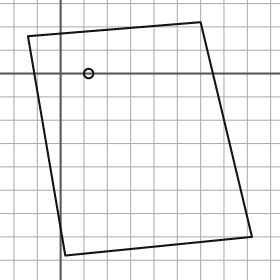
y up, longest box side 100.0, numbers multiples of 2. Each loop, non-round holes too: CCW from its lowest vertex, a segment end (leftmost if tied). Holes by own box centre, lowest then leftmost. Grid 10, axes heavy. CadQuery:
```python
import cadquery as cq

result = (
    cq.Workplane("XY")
    .moveTo(2.0, -78.0)
    .lineTo(82.0, -70.0)
    .lineTo(60.0, 22.0)
    .lineTo(-14.0, 16.0)
    .close()
    .moveTo(12.0, 0.0)
    .circle(2.0)
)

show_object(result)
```